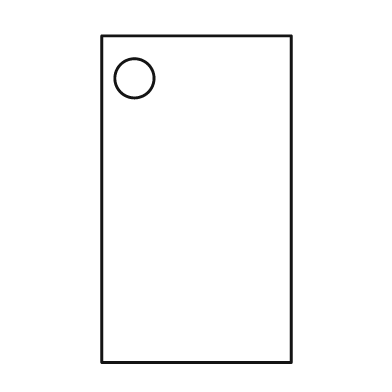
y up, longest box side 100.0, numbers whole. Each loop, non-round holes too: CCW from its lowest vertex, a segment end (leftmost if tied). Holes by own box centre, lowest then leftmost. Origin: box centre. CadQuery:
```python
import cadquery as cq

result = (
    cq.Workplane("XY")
    .moveTo(-29.0, -50.0)
    .lineTo(29.0, -50.0)
    .lineTo(29.0, 50.0)
    .lineTo(-29.0, 50.0)
    .close()
    .moveTo(-19.0, 37.0)
    .circle(6.0)
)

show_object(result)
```